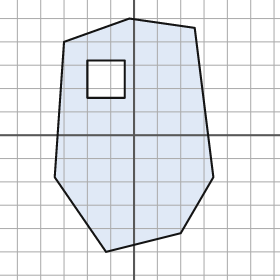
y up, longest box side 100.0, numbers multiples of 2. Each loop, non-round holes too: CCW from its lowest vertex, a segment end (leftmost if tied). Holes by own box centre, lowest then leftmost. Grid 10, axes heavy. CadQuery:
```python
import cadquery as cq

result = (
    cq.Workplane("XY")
    .moveTo(-12.0, -50.0)
    .lineTo(20.0, -42.0)
    .lineTo(34.0, -18.0)
    .lineTo(26.0, 46.0)
    .lineTo(-2.0, 50.0)
    .lineTo(-30.0, 40.0)
    .lineTo(-34.0, -18.0)
    .close()
    .moveTo(-20.0, 16.0)
    .lineTo(-4.0, 16.0)
    .lineTo(-4.0, 32.0)
    .lineTo(-20.0, 32.0)
    .close()
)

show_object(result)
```